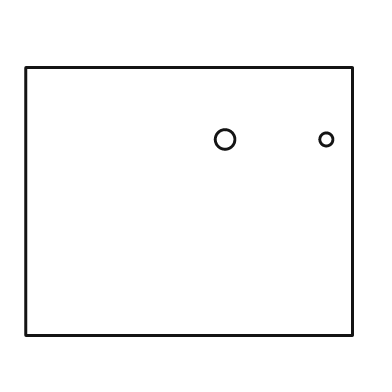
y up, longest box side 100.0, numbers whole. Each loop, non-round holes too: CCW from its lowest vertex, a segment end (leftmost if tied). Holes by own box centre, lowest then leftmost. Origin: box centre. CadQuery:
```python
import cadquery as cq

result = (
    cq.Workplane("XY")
    .moveTo(-50.0, -41.0)
    .lineTo(50.0, -41.0)
    .lineTo(50.0, 41.0)
    .lineTo(-50.0, 41.0)
    .close()
    .moveTo(11.0, 19.0)
    .circle(3.0)
    .moveTo(42.0, 19.0)
    .circle(2.0)
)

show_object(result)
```